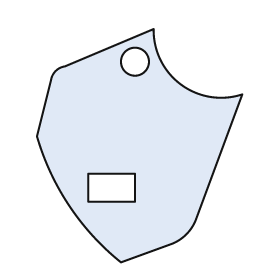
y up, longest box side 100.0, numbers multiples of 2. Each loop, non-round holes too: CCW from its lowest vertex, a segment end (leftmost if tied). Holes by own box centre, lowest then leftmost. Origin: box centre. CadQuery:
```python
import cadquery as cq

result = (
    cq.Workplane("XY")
    .moveTo(-8.0, -50.0)
    .lineTo(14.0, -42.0)
    .threePointArc((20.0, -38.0), (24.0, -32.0))
    .lineTo(44.0, 22.0)
    .threePointArc((18.0, 26.0), (6.0, 50.0))
    .lineTo(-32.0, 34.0)
    .threePointArc((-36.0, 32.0), (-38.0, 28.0))
    .lineTo(-44.0, 4.0)
    .threePointArc((-30.0, -26.0), (-8.0, -50.0))
    .close()
    .moveTo(-22.0, -24.0)
    .lineTo(-2.0, -24.0)
    .lineTo(-2.0, -12.0)
    .lineTo(-22.0, -12.0)
    .close()
    .moveTo(-2.0, 36.0)
    .circle(6.0)
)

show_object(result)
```